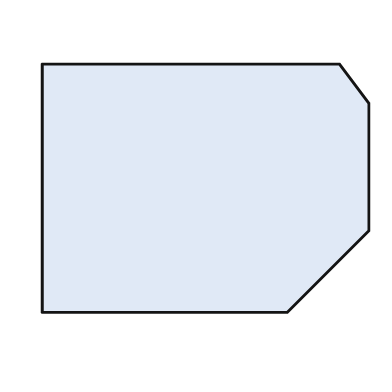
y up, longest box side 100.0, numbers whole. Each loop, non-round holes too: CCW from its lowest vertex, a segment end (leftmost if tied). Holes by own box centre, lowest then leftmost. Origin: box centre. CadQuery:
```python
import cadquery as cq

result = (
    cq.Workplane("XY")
    .moveTo(-50.0, -38.0)
    .lineTo(25.0, -38.0)
    .lineTo(50.0, -13.0)
    .lineTo(50.0, 26.0)
    .lineTo(41.0, 38.0)
    .lineTo(-50.0, 38.0)
    .close()
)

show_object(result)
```